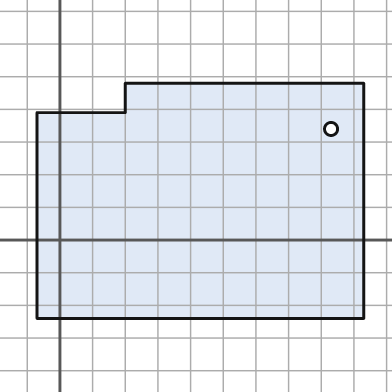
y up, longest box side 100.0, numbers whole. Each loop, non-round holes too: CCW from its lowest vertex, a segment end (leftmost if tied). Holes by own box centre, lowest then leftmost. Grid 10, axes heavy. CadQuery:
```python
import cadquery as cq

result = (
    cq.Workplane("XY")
    .moveTo(-7.0, -24.0)
    .lineTo(93.0, -24.0)
    .lineTo(93.0, 48.0)
    .lineTo(20.0, 48.0)
    .lineTo(20.0, 39.0)
    .lineTo(-7.0, 39.0)
    .close()
    .moveTo(83.0, 34.0)
    .circle(2.0)
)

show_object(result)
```